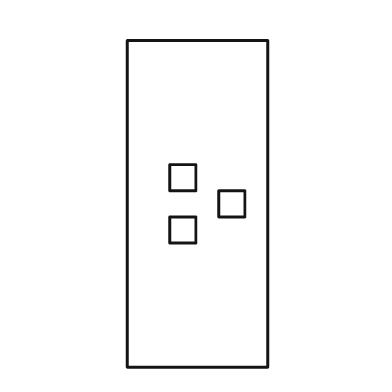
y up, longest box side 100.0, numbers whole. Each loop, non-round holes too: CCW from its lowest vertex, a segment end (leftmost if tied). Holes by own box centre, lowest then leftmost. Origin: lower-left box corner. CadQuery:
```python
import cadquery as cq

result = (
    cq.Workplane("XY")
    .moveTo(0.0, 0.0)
    .lineTo(43.0, 0.0)
    .lineTo(43.0, 100.0)
    .lineTo(0.0, 100.0)
    .close()
    .moveTo(13.0, 38.0)
    .lineTo(21.0, 38.0)
    .lineTo(21.0, 46.0)
    .lineTo(13.0, 46.0)
    .close()
    .moveTo(28.0, 46.0)
    .lineTo(36.0, 46.0)
    .lineTo(36.0, 54.0)
    .lineTo(28.0, 54.0)
    .close()
    .moveTo(13.0, 54.0)
    .lineTo(21.0, 54.0)
    .lineTo(21.0, 62.0)
    .lineTo(13.0, 62.0)
    .close()
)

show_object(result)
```